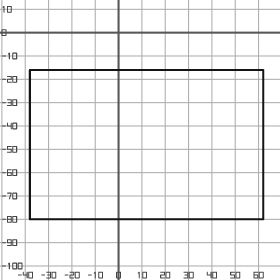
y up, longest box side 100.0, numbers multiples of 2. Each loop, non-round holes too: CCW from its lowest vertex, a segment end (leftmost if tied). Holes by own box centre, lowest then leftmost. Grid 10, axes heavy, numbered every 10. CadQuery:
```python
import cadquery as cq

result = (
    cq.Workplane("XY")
    .moveTo(-38.0, -80.0)
    .lineTo(62.0, -80.0)
    .lineTo(62.0, -16.0)
    .lineTo(-38.0, -16.0)
    .close()
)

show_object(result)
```